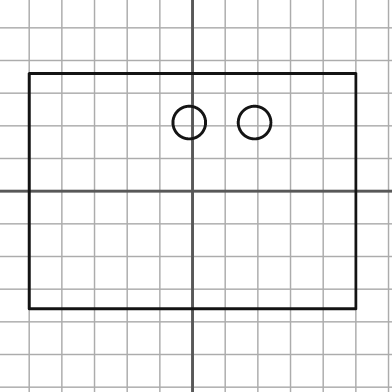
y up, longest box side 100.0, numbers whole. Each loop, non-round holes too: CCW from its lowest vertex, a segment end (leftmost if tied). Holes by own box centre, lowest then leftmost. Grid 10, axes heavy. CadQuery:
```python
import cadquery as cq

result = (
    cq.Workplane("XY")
    .moveTo(-50.0, -36.0)
    .lineTo(50.0, -36.0)
    .lineTo(50.0, 36.0)
    .lineTo(-50.0, 36.0)
    .close()
    .moveTo(-1.0, 21.0)
    .circle(5.0)
    .moveTo(19.0, 21.0)
    .circle(5.0)
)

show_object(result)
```